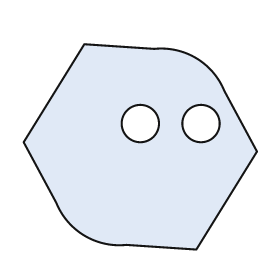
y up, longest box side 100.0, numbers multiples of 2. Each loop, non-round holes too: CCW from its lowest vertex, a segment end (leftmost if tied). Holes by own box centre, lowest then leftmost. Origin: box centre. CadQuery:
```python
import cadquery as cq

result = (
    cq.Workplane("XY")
    .moveTo(24.0, -44.0)
    .lineTo(50.0, -2.0)
    .lineTo(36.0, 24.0)
    .threePointArc((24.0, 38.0), (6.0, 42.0))
    .lineTo(-24.0, 44.0)
    .lineTo(-50.0, 2.0)
    .lineTo(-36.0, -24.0)
    .threePointArc((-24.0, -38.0), (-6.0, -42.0))
    .close()
    .moveTo(0.0, 10.0)
    .circle(8.0)
    .moveTo(26.0, 10.0)
    .circle(8.0)
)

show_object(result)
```